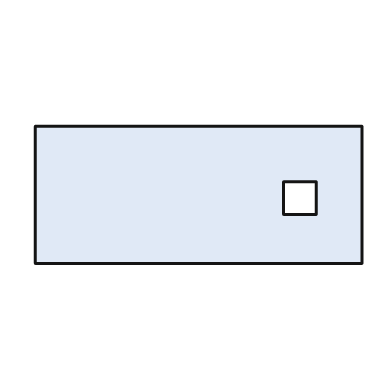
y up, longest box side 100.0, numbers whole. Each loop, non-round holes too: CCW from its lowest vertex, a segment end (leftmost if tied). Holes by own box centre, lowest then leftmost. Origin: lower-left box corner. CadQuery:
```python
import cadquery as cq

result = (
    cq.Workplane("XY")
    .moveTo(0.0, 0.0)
    .lineTo(100.0, 0.0)
    .lineTo(100.0, 42.0)
    .lineTo(0.0, 42.0)
    .close()
    .moveTo(76.0, 15.0)
    .lineTo(86.0, 15.0)
    .lineTo(86.0, 25.0)
    .lineTo(76.0, 25.0)
    .close()
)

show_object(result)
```